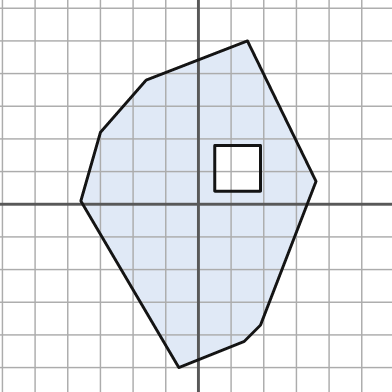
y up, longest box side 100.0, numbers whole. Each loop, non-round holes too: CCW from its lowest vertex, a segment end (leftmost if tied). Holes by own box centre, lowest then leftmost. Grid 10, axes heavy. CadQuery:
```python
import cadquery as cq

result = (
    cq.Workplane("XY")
    .moveTo(-6.0, -50.0)
    .lineTo(14.0, -42.0)
    .lineTo(19.0, -37.0)
    .lineTo(36.0, 7.0)
    .lineTo(15.0, 50.0)
    .lineTo(-16.0, 38.0)
    .lineTo(-30.0, 22.0)
    .lineTo(-36.0, 1.0)
    .close()
    .moveTo(5.0, 4.0)
    .lineTo(19.0, 4.0)
    .lineTo(19.0, 18.0)
    .lineTo(5.0, 18.0)
    .close()
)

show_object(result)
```